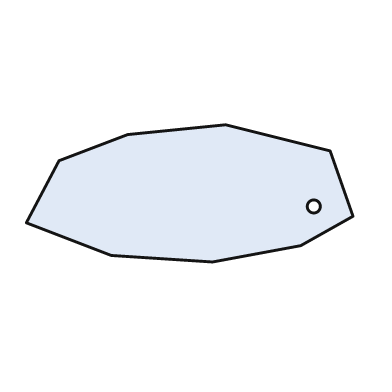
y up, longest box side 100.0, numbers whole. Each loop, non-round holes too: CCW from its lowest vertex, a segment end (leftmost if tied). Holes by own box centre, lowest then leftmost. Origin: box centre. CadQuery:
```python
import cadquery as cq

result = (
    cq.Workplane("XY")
    .moveTo(7.0, -21.0)
    .lineTo(34.0, -16.0)
    .lineTo(50.0, -7.0)
    .lineTo(43.0, 13.0)
    .lineTo(11.0, 21.0)
    .lineTo(-19.0, 18.0)
    .lineTo(-40.0, 10.0)
    .lineTo(-50.0, -9.0)
    .lineTo(-24.0, -19.0)
    .close()
    .moveTo(38.0, -4.0)
    .circle(2.0)
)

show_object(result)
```